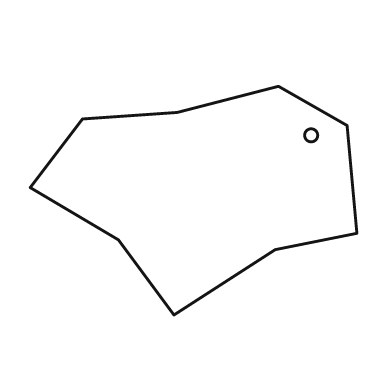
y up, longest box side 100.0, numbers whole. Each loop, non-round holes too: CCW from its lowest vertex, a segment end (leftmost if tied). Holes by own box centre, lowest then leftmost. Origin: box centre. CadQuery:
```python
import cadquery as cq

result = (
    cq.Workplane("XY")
    .moveTo(-6.0, -35.0)
    .lineTo(25.0, -15.0)
    .lineTo(50.0, -10.0)
    .lineTo(47.0, 23.0)
    .lineTo(26.0, 35.0)
    .lineTo(-5.0, 27.0)
    .lineTo(-34.0, 25.0)
    .lineTo(-50.0, 4.0)
    .lineTo(-23.0, -12.0)
    .close()
    .moveTo(36.0, 20.0)
    .circle(2.0)
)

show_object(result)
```